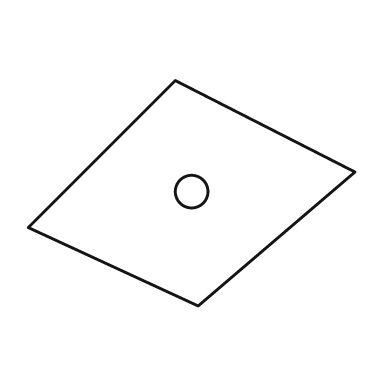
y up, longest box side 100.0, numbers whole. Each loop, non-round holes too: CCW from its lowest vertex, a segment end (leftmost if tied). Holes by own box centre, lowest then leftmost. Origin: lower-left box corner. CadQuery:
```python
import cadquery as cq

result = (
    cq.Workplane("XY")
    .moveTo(52.0, 0.0)
    .lineTo(100.0, 41.0)
    .lineTo(45.0, 69.0)
    .lineTo(0.0, 24.0)
    .close()
    .moveTo(50.0, 35.0)
    .circle(5.0)
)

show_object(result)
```